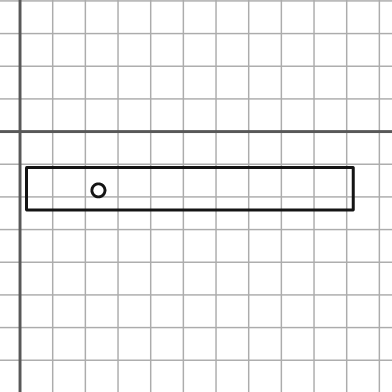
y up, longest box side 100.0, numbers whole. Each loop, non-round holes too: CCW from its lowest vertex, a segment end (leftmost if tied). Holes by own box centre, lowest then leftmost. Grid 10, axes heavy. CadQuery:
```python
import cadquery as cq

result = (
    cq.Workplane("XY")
    .moveTo(2.0, -24.0)
    .lineTo(102.0, -24.0)
    .lineTo(102.0, -11.0)
    .lineTo(2.0, -11.0)
    .close()
    .moveTo(24.0, -18.0)
    .circle(2.0)
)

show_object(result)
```